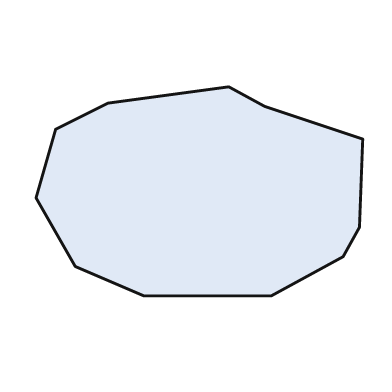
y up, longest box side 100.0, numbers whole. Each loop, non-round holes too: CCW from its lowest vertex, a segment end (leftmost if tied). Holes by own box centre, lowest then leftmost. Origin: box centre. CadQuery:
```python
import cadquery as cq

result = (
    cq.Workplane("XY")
    .moveTo(-17.0, -32.0)
    .lineTo(22.0, -32.0)
    .lineTo(44.0, -20.0)
    .lineTo(49.0, -11.0)
    .lineTo(50.0, 16.0)
    .lineTo(20.0, 26.0)
    .lineTo(9.0, 32.0)
    .lineTo(-28.0, 27.0)
    .lineTo(-44.0, 19.0)
    .lineTo(-50.0, -2.0)
    .lineTo(-38.0, -23.0)
    .close()
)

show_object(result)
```